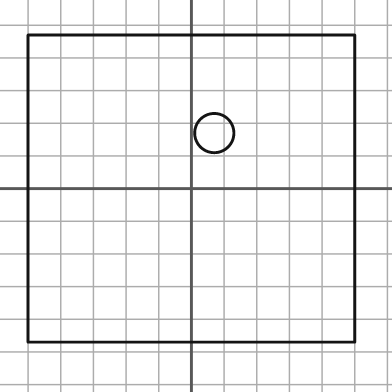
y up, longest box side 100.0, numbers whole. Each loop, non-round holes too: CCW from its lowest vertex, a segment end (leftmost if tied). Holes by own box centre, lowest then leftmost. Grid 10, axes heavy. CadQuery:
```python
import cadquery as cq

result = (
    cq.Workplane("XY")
    .moveTo(-50.0, -47.0)
    .lineTo(50.0, -47.0)
    .lineTo(50.0, 47.0)
    .lineTo(-50.0, 47.0)
    .close()
    .moveTo(7.0, 17.0)
    .circle(6.0)
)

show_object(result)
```